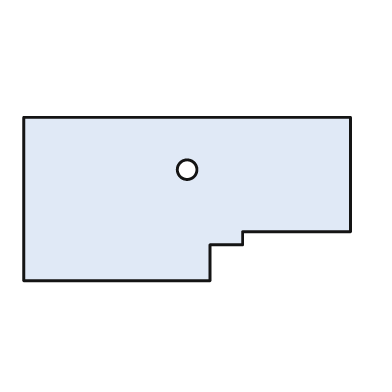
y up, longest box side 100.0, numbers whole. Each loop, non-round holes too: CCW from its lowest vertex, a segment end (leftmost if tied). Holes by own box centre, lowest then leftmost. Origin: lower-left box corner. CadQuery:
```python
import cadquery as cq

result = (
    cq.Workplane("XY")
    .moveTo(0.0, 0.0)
    .lineTo(57.0, 0.0)
    .lineTo(57.0, 11.0)
    .lineTo(67.0, 11.0)
    .lineTo(67.0, 15.0)
    .lineTo(100.0, 15.0)
    .lineTo(100.0, 50.0)
    .lineTo(0.0, 50.0)
    .close()
    .moveTo(50.0, 34.0)
    .circle(3.0)
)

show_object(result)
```